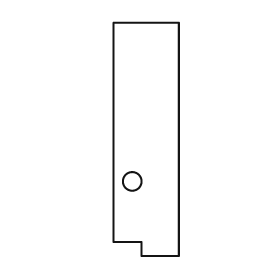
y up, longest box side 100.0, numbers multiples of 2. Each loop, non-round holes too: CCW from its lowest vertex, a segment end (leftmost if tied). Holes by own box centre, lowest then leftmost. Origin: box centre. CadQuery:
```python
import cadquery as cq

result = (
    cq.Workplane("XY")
    .moveTo(-2.0, -50.0)
    .lineTo(14.0, -50.0)
    .lineTo(14.0, 50.0)
    .lineTo(-14.0, 50.0)
    .lineTo(-14.0, -44.0)
    .lineTo(-2.0, -44.0)
    .close()
    .moveTo(-6.0, -18.0)
    .circle(4.0)
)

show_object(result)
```